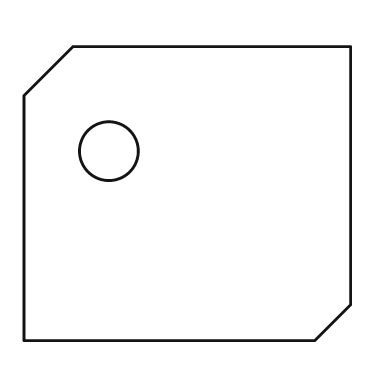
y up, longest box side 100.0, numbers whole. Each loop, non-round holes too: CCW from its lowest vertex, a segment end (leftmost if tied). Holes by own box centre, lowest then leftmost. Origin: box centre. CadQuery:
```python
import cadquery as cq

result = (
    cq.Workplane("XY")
    .moveTo(-50.0, -45.0)
    .lineTo(39.0, -45.0)
    .lineTo(50.0, -34.0)
    .lineTo(50.0, 45.0)
    .lineTo(-35.0, 45.0)
    .lineTo(-50.0, 30.0)
    .close()
    .moveTo(-24.0, 13.0)
    .circle(9.0)
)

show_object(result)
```